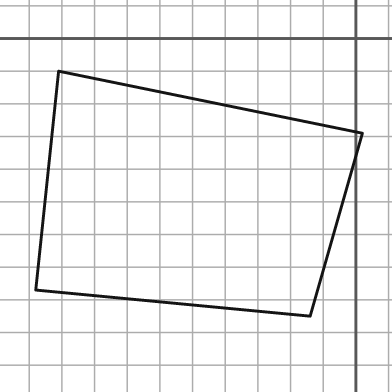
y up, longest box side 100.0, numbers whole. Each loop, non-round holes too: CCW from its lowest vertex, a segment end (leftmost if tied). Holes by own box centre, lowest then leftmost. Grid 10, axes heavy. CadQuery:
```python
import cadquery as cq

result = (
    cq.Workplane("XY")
    .moveTo(-14.0, -85.0)
    .lineTo(2.0, -29.0)
    .lineTo(-91.0, -10.0)
    .lineTo(-98.0, -77.0)
    .close()
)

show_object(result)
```